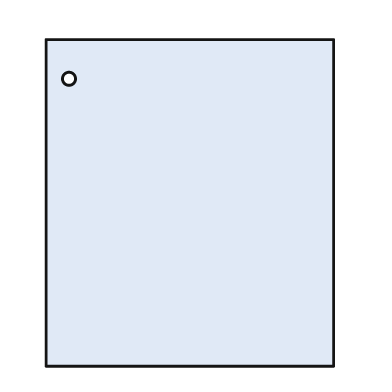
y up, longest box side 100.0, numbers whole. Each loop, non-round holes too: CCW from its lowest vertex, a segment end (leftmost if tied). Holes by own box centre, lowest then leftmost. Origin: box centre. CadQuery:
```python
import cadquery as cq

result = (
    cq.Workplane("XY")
    .moveTo(-44.0, -50.0)
    .lineTo(44.0, -50.0)
    .lineTo(44.0, 50.0)
    .lineTo(-44.0, 50.0)
    .close()
    .moveTo(-37.0, 38.0)
    .circle(2.0)
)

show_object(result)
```